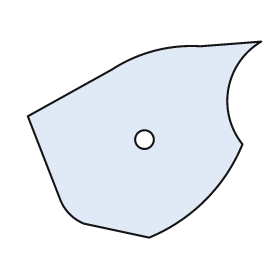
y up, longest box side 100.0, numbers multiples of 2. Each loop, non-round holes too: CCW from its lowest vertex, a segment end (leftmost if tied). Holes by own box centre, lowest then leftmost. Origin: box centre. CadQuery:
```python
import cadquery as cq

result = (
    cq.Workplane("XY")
    .moveTo(2.0, -42.0)
    .threePointArc((26.0, -26.0), (42.0, -2.0))
    .threePointArc((36.0, 22.0), (50.0, 42.0))
    .lineTo(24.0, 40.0)
    .threePointArc((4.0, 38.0), (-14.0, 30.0))
    .lineTo(-50.0, 10.0)
    .lineTo(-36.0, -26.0)
    .threePointArc((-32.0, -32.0), (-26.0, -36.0))
    .close()
    .moveTo(0.0, 0.0)
    .circle(4.0)
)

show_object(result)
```